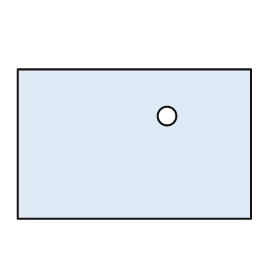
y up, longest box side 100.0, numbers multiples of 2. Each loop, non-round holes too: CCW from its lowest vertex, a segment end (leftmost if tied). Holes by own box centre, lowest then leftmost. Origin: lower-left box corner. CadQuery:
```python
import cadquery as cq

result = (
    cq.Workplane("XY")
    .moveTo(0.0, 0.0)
    .lineTo(100.0, 0.0)
    .lineTo(100.0, 64.0)
    .lineTo(0.0, 64.0)
    .close()
    .moveTo(64.0, 44.0)
    .circle(4.0)
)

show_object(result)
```